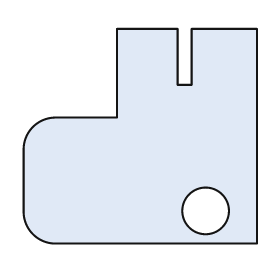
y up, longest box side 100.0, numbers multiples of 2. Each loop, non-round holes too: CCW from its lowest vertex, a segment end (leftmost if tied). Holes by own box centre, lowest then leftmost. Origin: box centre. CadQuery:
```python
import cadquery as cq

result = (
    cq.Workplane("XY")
    .moveTo(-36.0, -46.0)
    .lineTo(50.0, -46.0)
    .lineTo(50.0, 46.0)
    .lineTo(22.0, 46.0)
    .lineTo(22.0, 22.0)
    .lineTo(16.0, 22.0)
    .lineTo(16.0, 46.0)
    .lineTo(-10.0, 46.0)
    .lineTo(-10.0, 8.0)
    .lineTo(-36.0, 8.0)
    .threePointArc((-46.0, 4.0), (-50.0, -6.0))
    .lineTo(-50.0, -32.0)
    .threePointArc((-46.0, -42.0), (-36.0, -46.0))
    .close()
    .moveTo(28.0, -32.0)
    .circle(10.0)
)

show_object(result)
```